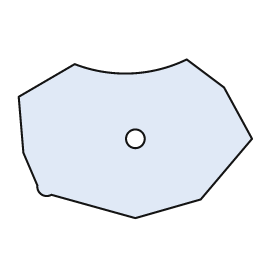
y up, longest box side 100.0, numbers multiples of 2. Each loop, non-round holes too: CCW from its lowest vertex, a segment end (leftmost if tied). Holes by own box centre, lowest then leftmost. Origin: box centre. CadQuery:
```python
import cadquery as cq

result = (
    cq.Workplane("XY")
    .moveTo(0.0, -34.0)
    .lineTo(28.0, -26.0)
    .lineTo(50.0, 0.0)
    .lineTo(38.0, 22.0)
    .lineTo(22.0, 34.0)
    .threePointArc((-2.0, 28.0), (-26.0, 32.0))
    .lineTo(-50.0, 18.0)
    .lineTo(-48.0, -6.0)
    .lineTo(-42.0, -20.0)
    .threePointArc((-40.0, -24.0), (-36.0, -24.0))
    .close()
    .moveTo(0.0, 0.0)
    .circle(4.0)
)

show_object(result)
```